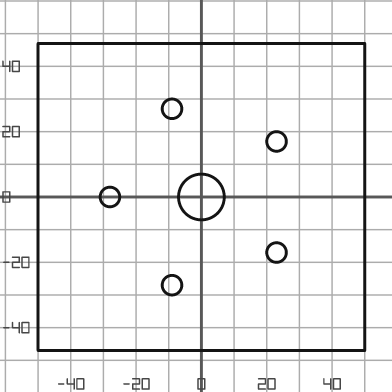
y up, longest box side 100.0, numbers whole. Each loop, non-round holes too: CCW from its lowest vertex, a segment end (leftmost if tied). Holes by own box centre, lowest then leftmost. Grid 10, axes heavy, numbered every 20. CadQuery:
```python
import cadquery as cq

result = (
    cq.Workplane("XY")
    .moveTo(-50.0, -47.0)
    .lineTo(50.0, -47.0)
    .lineTo(50.0, 47.0)
    .lineTo(-50.0, 47.0)
    .close()
    .moveTo(-9.0, -27.0)
    .circle(3.0)
    .moveTo(23.0, -17.0)
    .circle(3.0)
    .moveTo(-28.0, 0.0)
    .circle(3.0)
    .moveTo(0.0, 0.0)
    .circle(7.0)
    .moveTo(23.0, 17.0)
    .circle(3.0)
    .moveTo(-9.0, 27.0)
    .circle(3.0)
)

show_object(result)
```